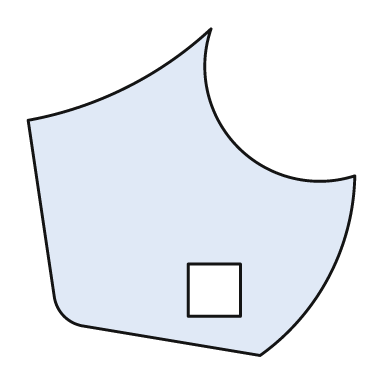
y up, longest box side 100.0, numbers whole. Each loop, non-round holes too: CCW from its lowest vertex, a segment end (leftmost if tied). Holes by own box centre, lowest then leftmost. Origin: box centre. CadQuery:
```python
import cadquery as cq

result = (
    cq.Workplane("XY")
    .moveTo(21.0, -50.0)
    .threePointArc((42.0, -26.0), (50.0, 5.0))
    .threePointArc((14.0, 14.0), (6.0, 50.0))
    .threePointArc((-20.0, 32.0), (-50.0, 22.0))
    .lineTo(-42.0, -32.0)
    .threePointArc((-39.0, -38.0), (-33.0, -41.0))
    .close()
    .moveTo(-1.0, -38.0)
    .lineTo(15.0, -38.0)
    .lineTo(15.0, -22.0)
    .lineTo(-1.0, -22.0)
    .close()
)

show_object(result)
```